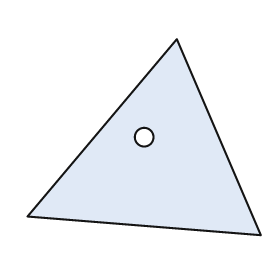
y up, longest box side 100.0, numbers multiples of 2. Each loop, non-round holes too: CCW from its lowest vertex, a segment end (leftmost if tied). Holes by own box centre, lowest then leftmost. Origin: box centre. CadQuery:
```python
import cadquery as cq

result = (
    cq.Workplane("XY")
    .moveTo(50.0, -42.0)
    .lineTo(14.0, 42.0)
    .lineTo(-50.0, -34.0)
    .close()
    .moveTo(0.0, 0.0)
    .circle(4.0)
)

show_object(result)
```